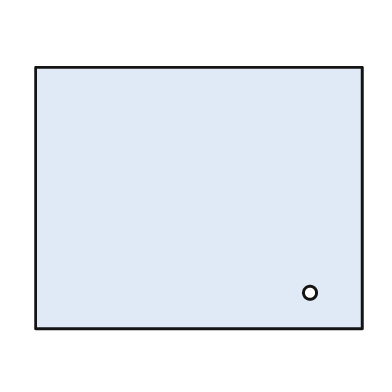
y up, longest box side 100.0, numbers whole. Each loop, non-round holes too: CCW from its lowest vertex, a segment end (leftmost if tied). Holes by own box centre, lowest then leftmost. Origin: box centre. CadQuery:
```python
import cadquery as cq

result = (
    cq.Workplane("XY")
    .moveTo(-50.0, -40.0)
    .lineTo(50.0, -40.0)
    .lineTo(50.0, 40.0)
    .lineTo(-50.0, 40.0)
    .close()
    .moveTo(34.0, -29.0)
    .circle(2.0)
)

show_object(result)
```